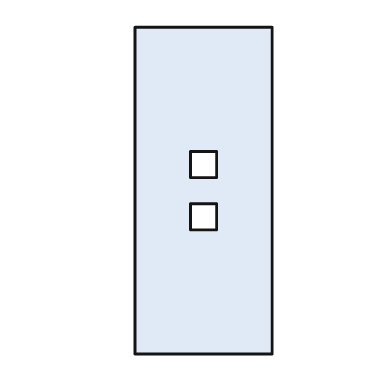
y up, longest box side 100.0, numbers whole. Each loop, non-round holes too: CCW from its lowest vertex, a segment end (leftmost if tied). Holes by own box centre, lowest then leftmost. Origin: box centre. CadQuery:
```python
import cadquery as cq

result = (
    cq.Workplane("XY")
    .moveTo(-21.0, -50.0)
    .lineTo(21.0, -50.0)
    .lineTo(21.0, 50.0)
    .lineTo(-21.0, 50.0)
    .close()
    .moveTo(-4.0, -12.0)
    .lineTo(4.0, -12.0)
    .lineTo(4.0, -4.0)
    .lineTo(-4.0, -4.0)
    .close()
    .moveTo(-4.0, 4.0)
    .lineTo(4.0, 4.0)
    .lineTo(4.0, 12.0)
    .lineTo(-4.0, 12.0)
    .close()
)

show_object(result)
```